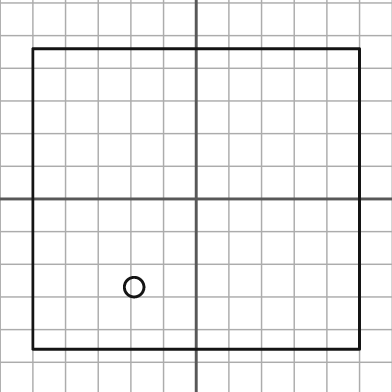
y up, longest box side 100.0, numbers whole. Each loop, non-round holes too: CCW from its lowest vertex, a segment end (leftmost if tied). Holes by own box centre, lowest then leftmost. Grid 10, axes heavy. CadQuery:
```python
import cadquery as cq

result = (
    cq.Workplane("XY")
    .moveTo(-50.0, -46.0)
    .lineTo(50.0, -46.0)
    .lineTo(50.0, 46.0)
    .lineTo(-50.0, 46.0)
    .close()
    .moveTo(-19.0, -27.0)
    .circle(3.0)
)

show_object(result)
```